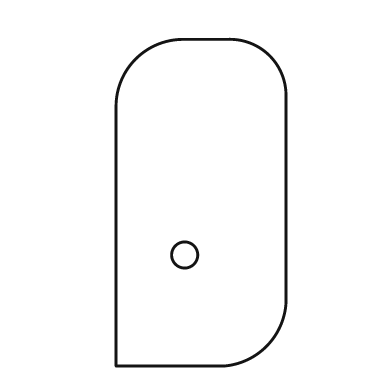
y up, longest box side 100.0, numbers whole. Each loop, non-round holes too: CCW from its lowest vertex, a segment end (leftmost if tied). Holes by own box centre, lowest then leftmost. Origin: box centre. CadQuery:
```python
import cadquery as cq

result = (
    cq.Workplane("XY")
    .moveTo(-26.0, -50.0)
    .lineTo(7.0, -50.0)
    .threePointArc((20.0, -44.0), (26.0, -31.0))
    .lineTo(26.0, 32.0)
    .threePointArc((21.0, 45.0), (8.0, 50.0))
    .lineTo(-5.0, 50.0)
    .threePointArc((-20.0, 44.0), (-26.0, 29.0))
    .close()
    .moveTo(-5.0, -16.0)
    .circle(4.0)
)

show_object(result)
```